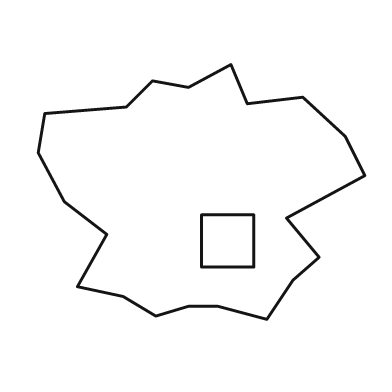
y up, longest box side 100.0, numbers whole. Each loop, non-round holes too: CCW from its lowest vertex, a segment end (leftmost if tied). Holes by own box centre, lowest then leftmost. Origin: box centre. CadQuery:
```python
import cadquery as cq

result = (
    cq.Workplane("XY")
    .moveTo(20.0, -39.0)
    .lineTo(28.0, -27.0)
    .lineTo(36.0, -20.0)
    .lineTo(26.0, -8.0)
    .lineTo(50.0, 5.0)
    .lineTo(44.0, 17.0)
    .lineTo(31.0, 29.0)
    .lineTo(14.0, 27.0)
    .lineTo(9.0, 39.0)
    .lineTo(-4.0, 32.0)
    .lineTo(-15.0, 34.0)
    .lineTo(-23.0, 26.0)
    .lineTo(-48.0, 24.0)
    .lineTo(-50.0, 12.0)
    .lineTo(-42.0, -3.0)
    .lineTo(-29.0, -13.0)
    .lineTo(-38.0, -29.0)
    .lineTo(-24.0, -32.0)
    .lineTo(-14.0, -38.0)
    .lineTo(-4.0, -35.0)
    .lineTo(5.0, -35.0)
    .close()
    .moveTo(0.0, -23.0)
    .lineTo(16.0, -23.0)
    .lineTo(16.0, -7.0)
    .lineTo(0.0, -7.0)
    .close()
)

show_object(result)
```